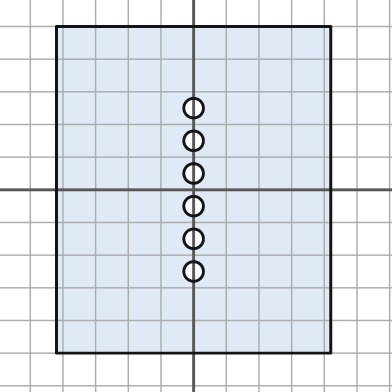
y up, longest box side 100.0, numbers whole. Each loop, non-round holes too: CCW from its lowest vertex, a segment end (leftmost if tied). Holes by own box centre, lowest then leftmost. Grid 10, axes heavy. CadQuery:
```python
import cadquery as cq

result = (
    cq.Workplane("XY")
    .moveTo(-42.0, -50.0)
    .lineTo(42.0, -50.0)
    .lineTo(42.0, 50.0)
    .lineTo(-42.0, 50.0)
    .close()
    .moveTo(0.0, -25.0)
    .circle(3.0)
    .moveTo(0.0, -15.0)
    .circle(3.0)
    .moveTo(0.0, -5.0)
    .circle(3.0)
    .moveTo(0.0, 5.0)
    .circle(3.0)
    .moveTo(0.0, 15.0)
    .circle(3.0)
    .moveTo(0.0, 25.0)
    .circle(3.0)
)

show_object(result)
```